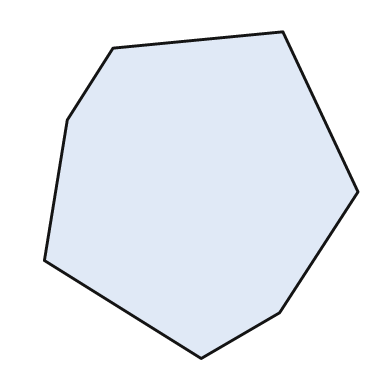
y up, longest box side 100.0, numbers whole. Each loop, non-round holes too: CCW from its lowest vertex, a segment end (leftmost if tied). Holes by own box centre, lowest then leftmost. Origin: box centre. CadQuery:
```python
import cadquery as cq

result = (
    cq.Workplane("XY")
    .moveTo(0.0, -50.0)
    .lineTo(24.0, -36.0)
    .lineTo(48.0, 1.0)
    .lineTo(25.0, 50.0)
    .lineTo(-27.0, 45.0)
    .lineTo(-41.0, 23.0)
    .lineTo(-48.0, -20.0)
    .close()
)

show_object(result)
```